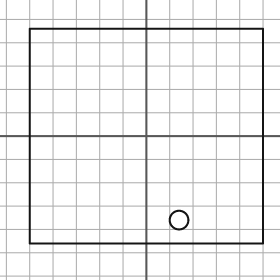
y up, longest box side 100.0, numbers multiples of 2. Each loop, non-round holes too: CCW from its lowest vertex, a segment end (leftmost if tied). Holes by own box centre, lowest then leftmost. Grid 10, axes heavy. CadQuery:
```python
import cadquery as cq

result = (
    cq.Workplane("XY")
    .moveTo(-50.0, -46.0)
    .lineTo(50.0, -46.0)
    .lineTo(50.0, 46.0)
    .lineTo(-50.0, 46.0)
    .close()
    .moveTo(14.0, -36.0)
    .circle(4.0)
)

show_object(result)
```